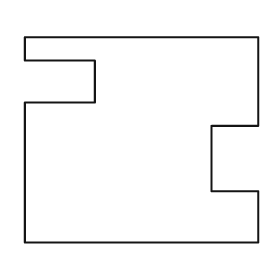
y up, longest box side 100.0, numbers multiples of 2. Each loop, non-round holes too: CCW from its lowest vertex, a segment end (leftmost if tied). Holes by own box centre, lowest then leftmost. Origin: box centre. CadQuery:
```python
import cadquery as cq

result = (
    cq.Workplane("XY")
    .moveTo(-50.0, -44.0)
    .lineTo(50.0, -44.0)
    .lineTo(50.0, -22.0)
    .lineTo(30.0, -22.0)
    .lineTo(30.0, 6.0)
    .lineTo(50.0, 6.0)
    .lineTo(50.0, 44.0)
    .lineTo(-50.0, 44.0)
    .lineTo(-50.0, 34.0)
    .lineTo(-20.0, 34.0)
    .lineTo(-20.0, 16.0)
    .lineTo(-50.0, 16.0)
    .close()
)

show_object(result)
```